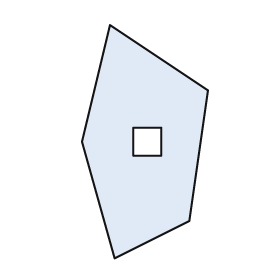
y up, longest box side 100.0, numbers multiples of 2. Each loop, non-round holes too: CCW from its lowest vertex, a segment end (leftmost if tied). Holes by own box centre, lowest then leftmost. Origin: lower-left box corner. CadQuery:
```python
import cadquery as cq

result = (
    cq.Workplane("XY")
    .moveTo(14.0, 0.0)
    .lineTo(46.0, 16.0)
    .lineTo(54.0, 72.0)
    .lineTo(12.0, 100.0)
    .lineTo(0.0, 50.0)
    .close()
    .moveTo(22.0, 44.0)
    .lineTo(34.0, 44.0)
    .lineTo(34.0, 56.0)
    .lineTo(22.0, 56.0)
    .close()
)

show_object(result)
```